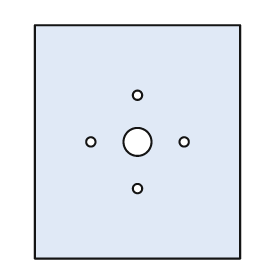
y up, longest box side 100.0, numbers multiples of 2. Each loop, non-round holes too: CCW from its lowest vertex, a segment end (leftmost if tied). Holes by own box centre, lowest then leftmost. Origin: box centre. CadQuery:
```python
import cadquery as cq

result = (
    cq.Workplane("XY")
    .moveTo(-44.0, -50.0)
    .lineTo(44.0, -50.0)
    .lineTo(44.0, 50.0)
    .lineTo(-44.0, 50.0)
    .close()
    .moveTo(0.0, -20.0)
    .circle(2.0)
    .moveTo(-20.0, 0.0)
    .circle(2.0)
    .moveTo(0.0, 0.0)
    .circle(6.0)
    .moveTo(20.0, 0.0)
    .circle(2.0)
    .moveTo(0.0, 20.0)
    .circle(2.0)
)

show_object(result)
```